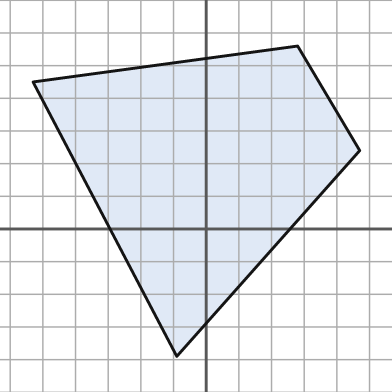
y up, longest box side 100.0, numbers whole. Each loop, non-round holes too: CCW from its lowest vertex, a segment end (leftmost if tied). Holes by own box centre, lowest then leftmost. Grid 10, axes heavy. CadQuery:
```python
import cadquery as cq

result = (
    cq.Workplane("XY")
    .moveTo(-9.0, -39.0)
    .lineTo(47.0, 24.0)
    .lineTo(28.0, 56.0)
    .lineTo(-53.0, 45.0)
    .close()
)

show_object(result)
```